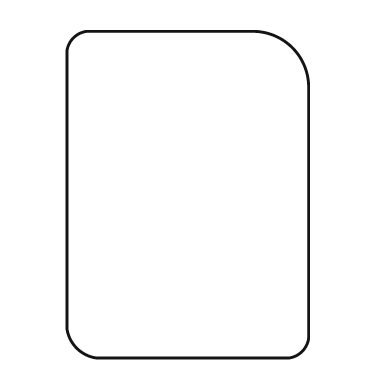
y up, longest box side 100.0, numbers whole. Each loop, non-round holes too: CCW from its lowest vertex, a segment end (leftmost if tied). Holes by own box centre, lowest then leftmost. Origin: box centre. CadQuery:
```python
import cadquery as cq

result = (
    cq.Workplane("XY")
    .moveTo(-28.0, -50.0)
    .lineTo(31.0, -50.0)
    .threePointArc((35.0, -48.0), (37.0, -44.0))
    .lineTo(37.0, 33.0)
    .threePointArc((32.0, 45.0), (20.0, 50.0))
    .lineTo(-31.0, 50.0)
    .threePointArc((-35.0, 48.0), (-37.0, 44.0))
    .lineTo(-37.0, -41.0)
    .threePointArc((-34.0, -47.0), (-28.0, -50.0))
    .close()
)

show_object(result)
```